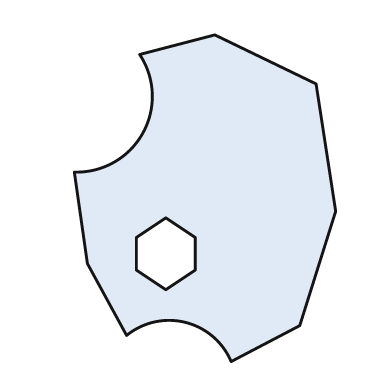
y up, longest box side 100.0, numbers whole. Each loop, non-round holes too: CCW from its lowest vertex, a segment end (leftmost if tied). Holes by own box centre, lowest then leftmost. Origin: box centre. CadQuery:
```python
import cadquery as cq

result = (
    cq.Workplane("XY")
    .moveTo(8.0, -50.0)
    .lineTo(29.0, -39.0)
    .lineTo(40.0, -4.0)
    .lineTo(34.0, 35.0)
    .lineTo(3.0, 50.0)
    .lineTo(-20.0, 44.0)
    .threePointArc((-19.0, 20.0), (-40.0, 8.0))
    .lineTo(-36.0, -20.0)
    .lineTo(-24.0, -42.0)
    .threePointArc((-6.0, -38.0), (8.0, -50.0))
    .close()
    .moveTo(-12.0, -28.0)
    .lineTo(-3.0, -22.0)
    .lineTo(-3.0, -12.0)
    .lineTo(-12.0, -6.0)
    .lineTo(-21.0, -12.0)
    .lineTo(-21.0, -22.0)
    .close()
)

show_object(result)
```